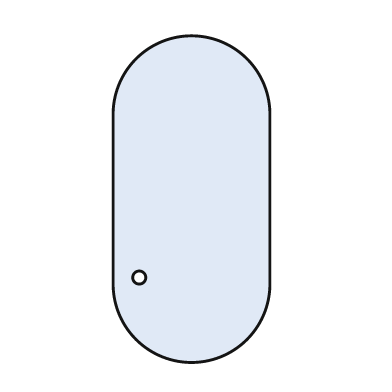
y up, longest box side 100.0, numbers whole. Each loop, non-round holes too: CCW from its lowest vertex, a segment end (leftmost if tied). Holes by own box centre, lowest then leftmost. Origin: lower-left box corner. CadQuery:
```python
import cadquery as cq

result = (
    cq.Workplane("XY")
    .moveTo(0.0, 24.0)
    .threePointArc((24.0, 0.0), (48.0, 24.0))
    .lineTo(48.0, 76.0)
    .threePointArc((24.0, 100.0), (0.0, 76.0))
    .close()
    .moveTo(8.0, 26.0)
    .circle(2.0)
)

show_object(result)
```